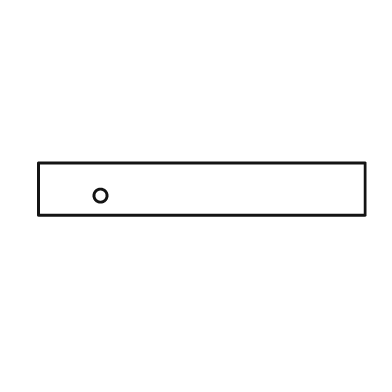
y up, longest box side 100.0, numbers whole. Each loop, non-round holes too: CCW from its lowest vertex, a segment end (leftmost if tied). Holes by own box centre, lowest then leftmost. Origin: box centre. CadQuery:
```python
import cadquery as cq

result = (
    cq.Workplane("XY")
    .moveTo(-50.0, -8.0)
    .lineTo(50.0, -8.0)
    .lineTo(50.0, 8.0)
    .lineTo(-50.0, 8.0)
    .close()
    .moveTo(-31.0, -2.0)
    .circle(2.0)
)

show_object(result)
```